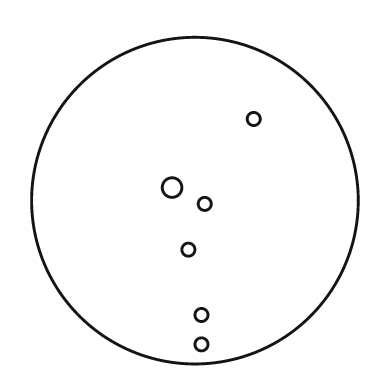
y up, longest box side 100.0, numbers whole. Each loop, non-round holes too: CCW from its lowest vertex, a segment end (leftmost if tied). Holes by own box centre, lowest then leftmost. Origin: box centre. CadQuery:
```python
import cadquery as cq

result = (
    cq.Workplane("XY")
    .moveTo(0.0, 0.0)
    .circle(50.0)
    .moveTo(2.0, -44.0)
    .circle(2.0)
    .moveTo(2.0, -35.0)
    .circle(2.0)
    .moveTo(-2.0, -15.0)
    .circle(2.0)
    .moveTo(3.0, -1.0)
    .circle(2.0)
    .moveTo(-7.0, 4.0)
    .circle(3.0)
    .moveTo(18.0, 25.0)
    .circle(2.0)
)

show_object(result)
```